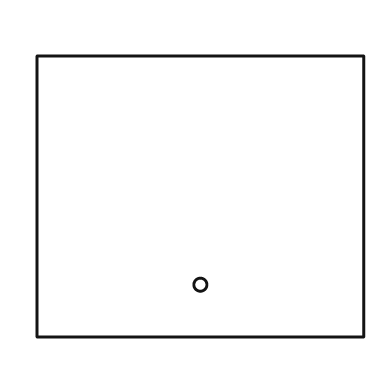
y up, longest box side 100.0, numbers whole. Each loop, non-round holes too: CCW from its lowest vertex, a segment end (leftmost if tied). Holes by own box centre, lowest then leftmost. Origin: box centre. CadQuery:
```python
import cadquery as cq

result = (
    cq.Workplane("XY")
    .moveTo(-50.0, -43.0)
    .lineTo(50.0, -43.0)
    .lineTo(50.0, 43.0)
    .lineTo(-50.0, 43.0)
    .close()
    .moveTo(0.0, -27.0)
    .circle(2.0)
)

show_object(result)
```